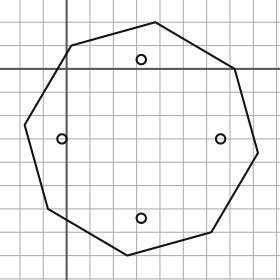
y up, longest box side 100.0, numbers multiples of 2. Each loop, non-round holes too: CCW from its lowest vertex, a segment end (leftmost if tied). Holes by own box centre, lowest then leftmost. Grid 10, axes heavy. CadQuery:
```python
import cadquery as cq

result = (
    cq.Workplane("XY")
    .moveTo(26.0, -80.0)
    .lineTo(62.0, -70.0)
    .lineTo(82.0, -36.0)
    .lineTo(72.0, 0.0)
    .lineTo(38.0, 20.0)
    .lineTo(2.0, 10.0)
    .lineTo(-18.0, -24.0)
    .lineTo(-8.0, -60.0)
    .close()
    .moveTo(32.0, -64.0)
    .circle(2.0)
    .moveTo(-2.0, -30.0)
    .circle(2.0)
    .moveTo(66.0, -30.0)
    .circle(2.0)
    .moveTo(32.0, 4.0)
    .circle(2.0)
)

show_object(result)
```